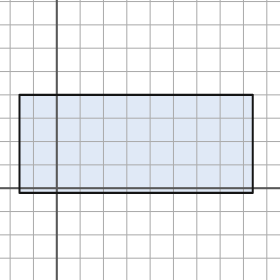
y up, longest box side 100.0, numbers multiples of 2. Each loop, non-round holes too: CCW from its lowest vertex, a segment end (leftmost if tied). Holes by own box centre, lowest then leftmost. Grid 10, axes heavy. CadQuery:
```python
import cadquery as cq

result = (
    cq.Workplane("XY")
    .moveTo(-16.0, -2.0)
    .lineTo(84.0, -2.0)
    .lineTo(84.0, 40.0)
    .lineTo(-16.0, 40.0)
    .close()
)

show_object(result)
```